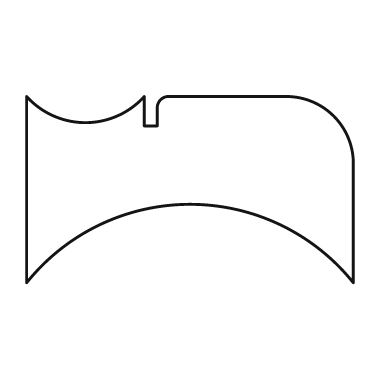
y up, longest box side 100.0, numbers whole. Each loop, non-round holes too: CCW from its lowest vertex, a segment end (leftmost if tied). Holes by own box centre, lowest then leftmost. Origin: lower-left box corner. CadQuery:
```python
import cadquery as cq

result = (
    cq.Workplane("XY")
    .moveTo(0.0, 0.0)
    .threePointArc((50.0, 24.0), (100.0, 0.0))
    .lineTo(100.0, 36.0)
    .threePointArc((94.0, 51.0), (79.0, 57.0))
    .lineTo(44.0, 57.0)
    .threePointArc((41.0, 56.0), (40.0, 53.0))
    .lineTo(40.0, 48.0)
    .lineTo(36.0, 48.0)
    .lineTo(36.0, 57.0)
    .threePointArc((18.0, 49.0), (0.0, 57.0))
    .close()
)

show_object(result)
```